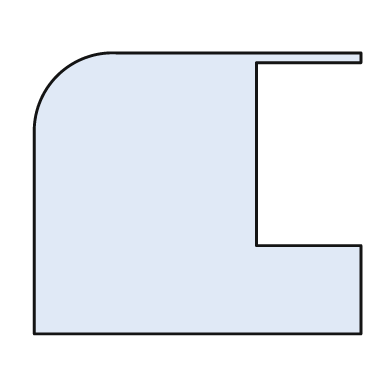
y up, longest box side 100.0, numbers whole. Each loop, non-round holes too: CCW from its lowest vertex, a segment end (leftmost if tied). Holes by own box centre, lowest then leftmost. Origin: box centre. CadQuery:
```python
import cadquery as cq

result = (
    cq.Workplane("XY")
    .moveTo(-50.0, -43.0)
    .lineTo(50.0, -43.0)
    .lineTo(50.0, -16.0)
    .lineTo(18.0, -16.0)
    .lineTo(18.0, 40.0)
    .lineTo(50.0, 40.0)
    .lineTo(50.0, 43.0)
    .lineTo(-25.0, 43.0)
    .threePointArc((-43.0, 36.0), (-50.0, 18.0))
    .close()
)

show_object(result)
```